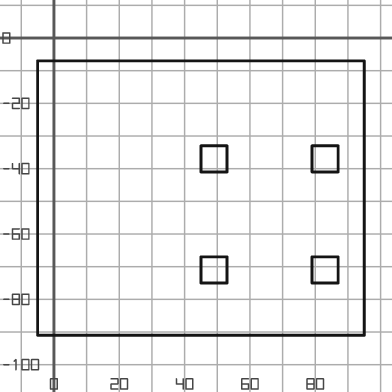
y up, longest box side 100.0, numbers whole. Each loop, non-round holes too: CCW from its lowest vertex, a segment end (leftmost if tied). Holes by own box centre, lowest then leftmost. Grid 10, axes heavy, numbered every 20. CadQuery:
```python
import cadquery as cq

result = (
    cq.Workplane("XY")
    .moveTo(-5.0, -91.0)
    .lineTo(95.0, -91.0)
    .lineTo(95.0, -7.0)
    .lineTo(-5.0, -7.0)
    .close()
    .moveTo(45.0, -75.0)
    .lineTo(53.0, -75.0)
    .lineTo(53.0, -67.0)
    .lineTo(45.0, -67.0)
    .close()
    .moveTo(79.0, -75.0)
    .lineTo(87.0, -75.0)
    .lineTo(87.0, -67.0)
    .lineTo(79.0, -67.0)
    .close()
    .moveTo(45.0, -41.0)
    .lineTo(53.0, -41.0)
    .lineTo(53.0, -33.0)
    .lineTo(45.0, -33.0)
    .close()
    .moveTo(79.0, -41.0)
    .lineTo(87.0, -41.0)
    .lineTo(87.0, -33.0)
    .lineTo(79.0, -33.0)
    .close()
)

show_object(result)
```